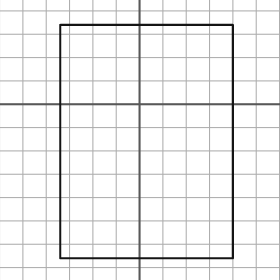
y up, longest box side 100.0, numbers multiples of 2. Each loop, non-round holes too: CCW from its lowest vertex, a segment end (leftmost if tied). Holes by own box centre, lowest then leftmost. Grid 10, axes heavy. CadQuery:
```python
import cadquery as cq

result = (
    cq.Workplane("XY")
    .moveTo(-34.0, -66.0)
    .lineTo(40.0, -66.0)
    .lineTo(40.0, 34.0)
    .lineTo(-34.0, 34.0)
    .close()
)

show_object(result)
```